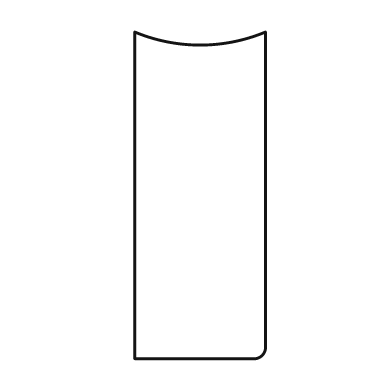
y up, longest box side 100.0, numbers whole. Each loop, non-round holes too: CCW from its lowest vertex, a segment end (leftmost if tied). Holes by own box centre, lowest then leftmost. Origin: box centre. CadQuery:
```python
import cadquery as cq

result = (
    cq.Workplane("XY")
    .moveTo(-20.0, -50.0)
    .lineTo(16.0, -50.0)
    .threePointArc((19.0, -49.0), (20.0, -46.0))
    .lineTo(20.0, 50.0)
    .threePointArc((0.0, 46.0), (-20.0, 50.0))
    .close()
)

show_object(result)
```